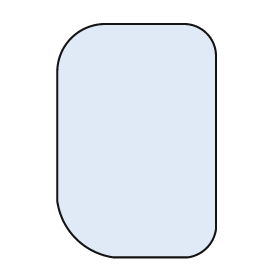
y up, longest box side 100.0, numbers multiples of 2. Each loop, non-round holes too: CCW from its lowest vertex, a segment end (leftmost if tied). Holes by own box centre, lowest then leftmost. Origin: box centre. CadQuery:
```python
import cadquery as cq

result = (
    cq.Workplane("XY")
    .moveTo(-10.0, -50.0)
    .lineTo(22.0, -50.0)
    .threePointArc((30.0, -46.0), (34.0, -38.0))
    .lineTo(34.0, 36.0)
    .threePointArc((30.0, 46.0), (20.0, 50.0))
    .lineTo(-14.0, 50.0)
    .threePointArc((-28.0, 44.0), (-34.0, 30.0))
    .lineTo(-34.0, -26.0)
    .threePointArc((-26.0, -42.0), (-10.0, -50.0))
    .close()
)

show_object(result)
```